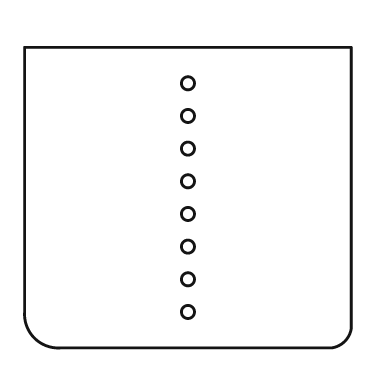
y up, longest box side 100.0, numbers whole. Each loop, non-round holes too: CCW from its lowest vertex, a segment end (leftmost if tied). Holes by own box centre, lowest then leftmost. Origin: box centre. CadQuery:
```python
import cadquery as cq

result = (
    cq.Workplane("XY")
    .moveTo(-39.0, -46.0)
    .lineTo(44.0, -46.0)
    .threePointArc((48.0, -44.0), (50.0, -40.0))
    .lineTo(50.0, 46.0)
    .lineTo(-50.0, 46.0)
    .lineTo(-50.0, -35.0)
    .threePointArc((-47.0, -43.0), (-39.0, -46.0))
    .close()
    .moveTo(0.0, -35.0)
    .circle(2.0)
    .moveTo(0.0, -25.0)
    .circle(2.0)
    .moveTo(0.0, -15.0)
    .circle(2.0)
    .moveTo(0.0, -5.0)
    .circle(2.0)
    .moveTo(0.0, 5.0)
    .circle(2.0)
    .moveTo(0.0, 15.0)
    .circle(2.0)
    .moveTo(0.0, 25.0)
    .circle(2.0)
    .moveTo(0.0, 35.0)
    .circle(2.0)
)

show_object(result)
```